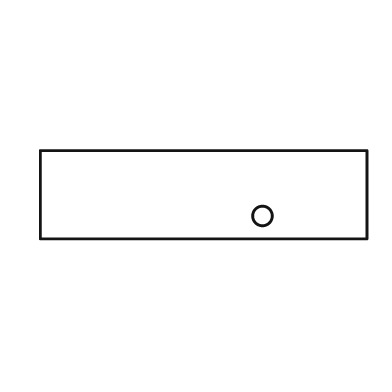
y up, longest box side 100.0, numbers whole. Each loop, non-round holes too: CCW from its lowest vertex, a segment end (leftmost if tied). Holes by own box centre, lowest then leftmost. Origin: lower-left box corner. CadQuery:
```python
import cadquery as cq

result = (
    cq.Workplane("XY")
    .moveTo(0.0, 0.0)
    .lineTo(100.0, 0.0)
    .lineTo(100.0, 27.0)
    .lineTo(0.0, 27.0)
    .close()
    .moveTo(68.0, 7.0)
    .circle(3.0)
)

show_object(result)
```